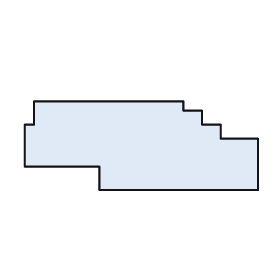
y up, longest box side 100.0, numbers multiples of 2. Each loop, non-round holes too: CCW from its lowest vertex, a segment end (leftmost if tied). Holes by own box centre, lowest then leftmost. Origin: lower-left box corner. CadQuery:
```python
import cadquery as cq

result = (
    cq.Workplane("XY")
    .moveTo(32.0, 0.0)
    .lineTo(100.0, 0.0)
    .lineTo(100.0, 22.0)
    .lineTo(84.0, 22.0)
    .lineTo(84.0, 28.0)
    .lineTo(76.0, 28.0)
    .lineTo(76.0, 34.0)
    .lineTo(68.0, 34.0)
    .lineTo(68.0, 38.0)
    .lineTo(4.0, 38.0)
    .lineTo(4.0, 28.0)
    .lineTo(0.0, 28.0)
    .lineTo(0.0, 10.0)
    .lineTo(32.0, 10.0)
    .close()
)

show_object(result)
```